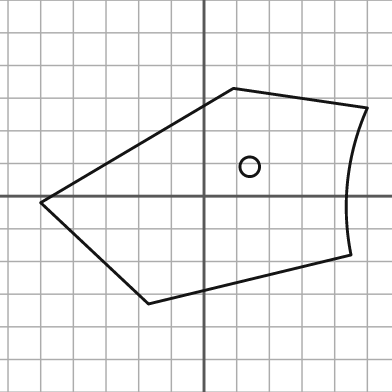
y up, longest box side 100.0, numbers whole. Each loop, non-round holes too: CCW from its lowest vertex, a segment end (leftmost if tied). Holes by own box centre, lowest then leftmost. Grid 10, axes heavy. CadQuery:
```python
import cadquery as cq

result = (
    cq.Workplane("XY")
    .moveTo(-17.0, -33.0)
    .lineTo(45.0, -18.0)
    .threePointArc((44.0, 5.0), (50.0, 27.0))
    .lineTo(9.0, 33.0)
    .lineTo(-50.0, -2.0)
    .close()
    .moveTo(14.0, 9.0)
    .circle(3.0)
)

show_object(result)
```